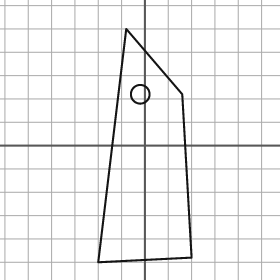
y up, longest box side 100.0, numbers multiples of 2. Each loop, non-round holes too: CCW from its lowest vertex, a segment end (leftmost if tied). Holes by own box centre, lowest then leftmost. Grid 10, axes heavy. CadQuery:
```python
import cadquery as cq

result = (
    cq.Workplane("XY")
    .moveTo(-20.0, -50.0)
    .lineTo(20.0, -48.0)
    .lineTo(16.0, 22.0)
    .lineTo(-8.0, 50.0)
    .close()
    .moveTo(-2.0, 22.0)
    .circle(4.0)
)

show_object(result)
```